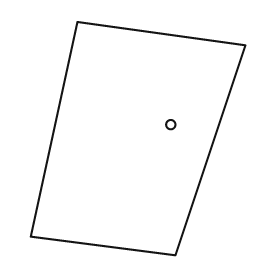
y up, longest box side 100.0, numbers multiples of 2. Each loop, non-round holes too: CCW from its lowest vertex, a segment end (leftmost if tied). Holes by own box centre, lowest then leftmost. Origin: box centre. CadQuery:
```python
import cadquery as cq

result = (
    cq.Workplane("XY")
    .moveTo(16.0, -50.0)
    .lineTo(46.0, 40.0)
    .lineTo(-26.0, 50.0)
    .lineTo(-46.0, -42.0)
    .close()
    .moveTo(14.0, 6.0)
    .circle(2.0)
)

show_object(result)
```